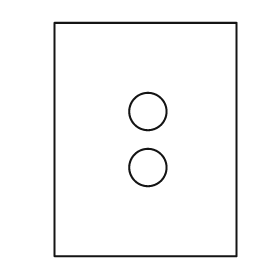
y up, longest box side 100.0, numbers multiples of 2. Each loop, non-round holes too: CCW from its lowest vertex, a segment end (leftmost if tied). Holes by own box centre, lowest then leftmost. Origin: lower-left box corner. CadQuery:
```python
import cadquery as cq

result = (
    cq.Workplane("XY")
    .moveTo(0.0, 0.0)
    .lineTo(78.0, 0.0)
    .lineTo(78.0, 100.0)
    .lineTo(0.0, 100.0)
    .close()
    .moveTo(40.0, 38.0)
    .circle(8.0)
    .moveTo(40.0, 62.0)
    .circle(8.0)
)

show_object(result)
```